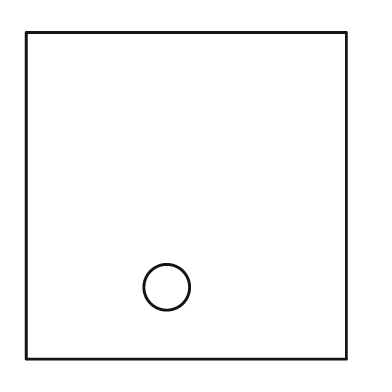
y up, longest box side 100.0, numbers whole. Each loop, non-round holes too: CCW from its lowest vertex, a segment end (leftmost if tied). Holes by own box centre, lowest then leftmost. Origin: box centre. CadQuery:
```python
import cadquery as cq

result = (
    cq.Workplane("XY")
    .moveTo(-49.0, -50.0)
    .lineTo(49.0, -50.0)
    .lineTo(49.0, 50.0)
    .lineTo(-49.0, 50.0)
    .close()
    .moveTo(-6.0, -28.0)
    .circle(7.0)
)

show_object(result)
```